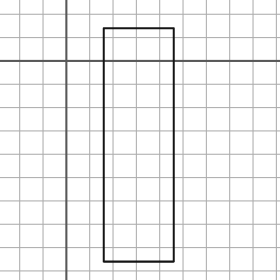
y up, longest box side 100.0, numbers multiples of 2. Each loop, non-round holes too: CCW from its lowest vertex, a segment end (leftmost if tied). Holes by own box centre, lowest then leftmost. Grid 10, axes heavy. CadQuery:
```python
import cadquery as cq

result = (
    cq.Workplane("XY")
    .moveTo(16.0, -86.0)
    .lineTo(46.0, -86.0)
    .lineTo(46.0, 14.0)
    .lineTo(16.0, 14.0)
    .close()
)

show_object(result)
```